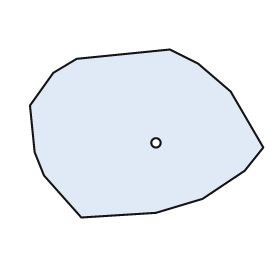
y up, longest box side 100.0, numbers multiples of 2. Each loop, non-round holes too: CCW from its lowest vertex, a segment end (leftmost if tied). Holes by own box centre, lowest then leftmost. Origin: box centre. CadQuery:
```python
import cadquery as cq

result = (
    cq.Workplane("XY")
    .moveTo(-28.0, -36.0)
    .lineTo(4.0, -34.0)
    .lineTo(24.0, -28.0)
    .lineTo(42.0, -16.0)
    .lineTo(50.0, -6.0)
    .lineTo(36.0, 18.0)
    .lineTo(22.0, 30.0)
    .lineTo(10.0, 36.0)
    .lineTo(-30.0, 32.0)
    .lineTo(-40.0, 26.0)
    .lineTo(-50.0, 12.0)
    .lineTo(-48.0, -8.0)
    .lineTo(-44.0, -18.0)
    .close()
    .moveTo(4.0, -4.0)
    .circle(2.0)
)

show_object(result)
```